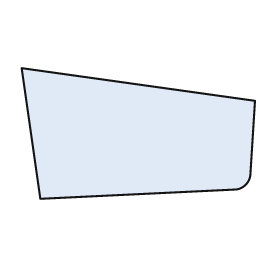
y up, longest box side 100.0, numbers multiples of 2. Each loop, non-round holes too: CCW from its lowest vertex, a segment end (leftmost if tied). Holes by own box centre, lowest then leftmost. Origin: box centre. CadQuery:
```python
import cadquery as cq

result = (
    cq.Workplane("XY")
    .moveTo(-42.0, -28.0)
    .lineTo(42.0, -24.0)
    .threePointArc((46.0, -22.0), (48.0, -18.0))
    .lineTo(50.0, 14.0)
    .lineTo(-50.0, 28.0)
    .close()
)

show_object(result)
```